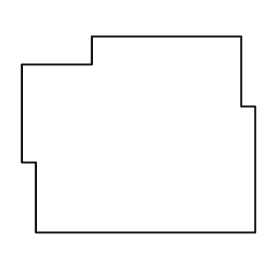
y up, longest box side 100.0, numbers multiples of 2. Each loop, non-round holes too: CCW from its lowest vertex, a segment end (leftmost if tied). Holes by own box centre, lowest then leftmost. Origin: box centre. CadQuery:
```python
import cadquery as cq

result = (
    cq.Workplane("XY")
    .moveTo(-44.0, -42.0)
    .lineTo(50.0, -42.0)
    .lineTo(50.0, 12.0)
    .lineTo(44.0, 12.0)
    .lineTo(44.0, 42.0)
    .lineTo(-20.0, 42.0)
    .lineTo(-20.0, 30.0)
    .lineTo(-50.0, 30.0)
    .lineTo(-50.0, -12.0)
    .lineTo(-44.0, -12.0)
    .close()
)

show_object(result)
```